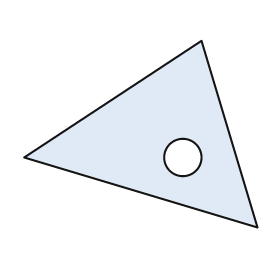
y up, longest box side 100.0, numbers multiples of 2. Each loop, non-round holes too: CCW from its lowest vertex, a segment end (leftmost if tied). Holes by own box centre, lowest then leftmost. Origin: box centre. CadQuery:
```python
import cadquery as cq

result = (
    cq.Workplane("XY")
    .moveTo(50.0, -40.0)
    .lineTo(26.0, 40.0)
    .lineTo(-50.0, -10.0)
    .close()
    .moveTo(18.0, -10.0)
    .circle(8.0)
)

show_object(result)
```